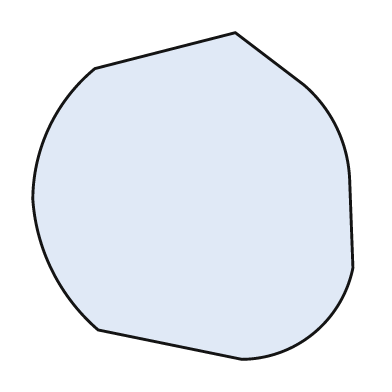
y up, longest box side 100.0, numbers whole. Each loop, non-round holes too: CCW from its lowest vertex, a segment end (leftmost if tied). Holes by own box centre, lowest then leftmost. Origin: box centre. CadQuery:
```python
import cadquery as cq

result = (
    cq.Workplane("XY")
    .moveTo(15.0, -50.0)
    .threePointArc((37.0, -42.0), (49.0, -22.0))
    .lineTo(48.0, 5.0)
    .threePointArc((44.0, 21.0), (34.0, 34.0))
    .lineTo(13.0, 50.0)
    .lineTo(-30.0, 39.0)
    .threePointArc((-44.0, 21.0), (-49.0, -1.0))
    .threePointArc((-43.0, -23.0), (-29.0, -41.0))
    .close()
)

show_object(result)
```